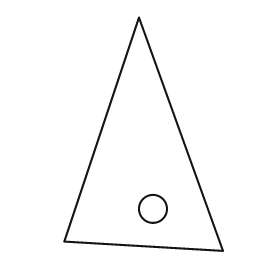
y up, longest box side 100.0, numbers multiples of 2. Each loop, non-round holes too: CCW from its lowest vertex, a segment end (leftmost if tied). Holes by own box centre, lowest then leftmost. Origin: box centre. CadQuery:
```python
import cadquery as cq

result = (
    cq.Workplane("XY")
    .moveTo(34.0, -50.0)
    .lineTo(-2.0, 50.0)
    .lineTo(-34.0, -46.0)
    .close()
    .moveTo(4.0, -32.0)
    .circle(6.0)
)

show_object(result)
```